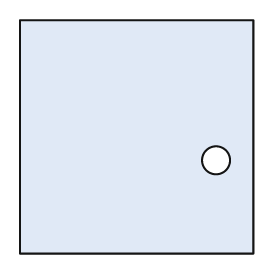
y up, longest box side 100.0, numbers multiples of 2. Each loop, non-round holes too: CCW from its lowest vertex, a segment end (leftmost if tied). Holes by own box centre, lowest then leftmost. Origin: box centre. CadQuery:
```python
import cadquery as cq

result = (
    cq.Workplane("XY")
    .moveTo(-50.0, -50.0)
    .lineTo(50.0, -50.0)
    .lineTo(50.0, 50.0)
    .lineTo(-50.0, 50.0)
    .close()
    .moveTo(34.0, -10.0)
    .circle(6.0)
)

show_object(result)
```